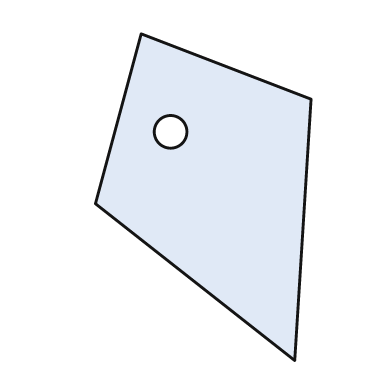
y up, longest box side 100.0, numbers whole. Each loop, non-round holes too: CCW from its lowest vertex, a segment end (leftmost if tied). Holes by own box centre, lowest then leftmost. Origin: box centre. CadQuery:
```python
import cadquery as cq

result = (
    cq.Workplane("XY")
    .moveTo(28.0, -50.0)
    .lineTo(33.0, 30.0)
    .lineTo(-19.0, 50.0)
    .lineTo(-33.0, -2.0)
    .close()
    .moveTo(-10.0, 20.0)
    .circle(5.0)
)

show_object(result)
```